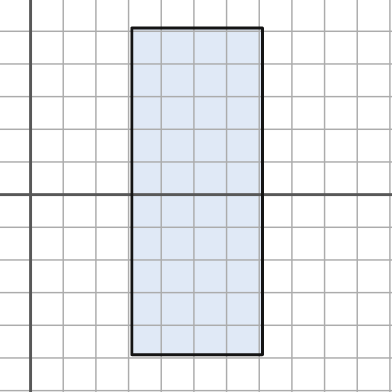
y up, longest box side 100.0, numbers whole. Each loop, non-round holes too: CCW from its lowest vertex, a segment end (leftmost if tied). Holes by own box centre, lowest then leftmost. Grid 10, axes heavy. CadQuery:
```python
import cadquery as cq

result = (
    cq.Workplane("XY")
    .moveTo(31.0, -49.0)
    .lineTo(71.0, -49.0)
    .lineTo(71.0, 51.0)
    .lineTo(31.0, 51.0)
    .close()
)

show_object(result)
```